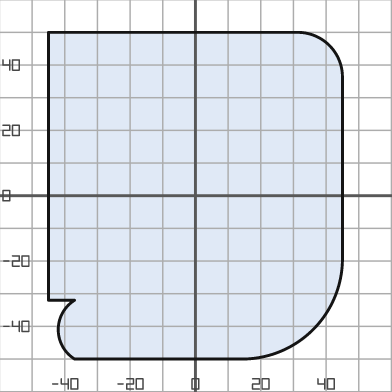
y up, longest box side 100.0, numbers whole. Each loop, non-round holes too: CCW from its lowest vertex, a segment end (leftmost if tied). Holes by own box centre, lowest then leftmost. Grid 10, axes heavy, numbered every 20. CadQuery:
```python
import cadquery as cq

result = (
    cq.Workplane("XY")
    .moveTo(-37.0, -50.0)
    .lineTo(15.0, -50.0)
    .threePointArc((36.0, -41.0), (45.0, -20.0))
    .lineTo(45.0, 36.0)
    .threePointArc((41.0, 46.0), (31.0, 50.0))
    .lineTo(-45.0, 50.0)
    .lineTo(-45.0, -32.0)
    .lineTo(-37.0, -32.0)
    .threePointArc((-42.0, -41.0), (-37.0, -50.0))
    .close()
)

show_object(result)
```